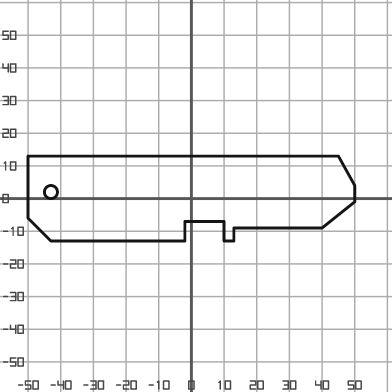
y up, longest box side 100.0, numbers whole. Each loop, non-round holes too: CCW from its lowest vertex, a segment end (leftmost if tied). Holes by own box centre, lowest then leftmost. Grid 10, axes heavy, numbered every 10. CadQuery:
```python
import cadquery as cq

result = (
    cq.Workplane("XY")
    .moveTo(-43.0, -13.0)
    .lineTo(-2.0, -13.0)
    .lineTo(-2.0, -7.0)
    .lineTo(10.0, -7.0)
    .lineTo(10.0, -13.0)
    .lineTo(13.0, -13.0)
    .lineTo(13.0, -9.0)
    .lineTo(40.0, -9.0)
    .lineTo(50.0, -1.0)
    .lineTo(50.0, 4.0)
    .lineTo(45.0, 13.0)
    .lineTo(-50.0, 13.0)
    .lineTo(-50.0, -6.0)
    .close()
    .moveTo(-43.0, 2.0)
    .circle(2.0)
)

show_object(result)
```